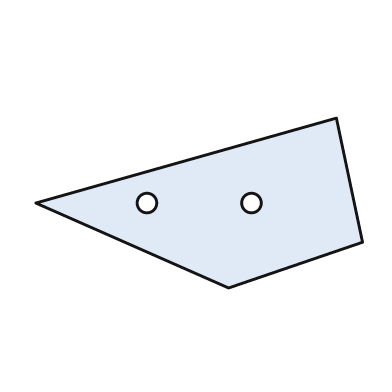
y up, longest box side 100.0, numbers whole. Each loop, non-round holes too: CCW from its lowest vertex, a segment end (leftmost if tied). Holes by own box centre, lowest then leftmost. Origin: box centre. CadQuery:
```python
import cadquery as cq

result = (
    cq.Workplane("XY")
    .moveTo(9.0, -26.0)
    .lineTo(50.0, -12.0)
    .lineTo(42.0, 26.0)
    .lineTo(-50.0, 0.0)
    .close()
    .moveTo(-16.0, 0.0)
    .circle(3.0)
    .moveTo(16.0, 0.0)
    .circle(3.0)
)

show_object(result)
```